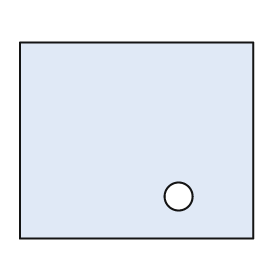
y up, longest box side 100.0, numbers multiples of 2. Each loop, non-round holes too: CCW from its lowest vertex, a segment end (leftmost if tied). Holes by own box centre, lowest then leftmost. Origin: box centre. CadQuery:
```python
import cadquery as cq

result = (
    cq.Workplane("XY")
    .moveTo(-50.0, -42.0)
    .lineTo(50.0, -42.0)
    .lineTo(50.0, 42.0)
    .lineTo(-50.0, 42.0)
    .close()
    .moveTo(18.0, -24.0)
    .circle(6.0)
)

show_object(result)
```